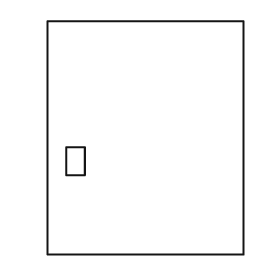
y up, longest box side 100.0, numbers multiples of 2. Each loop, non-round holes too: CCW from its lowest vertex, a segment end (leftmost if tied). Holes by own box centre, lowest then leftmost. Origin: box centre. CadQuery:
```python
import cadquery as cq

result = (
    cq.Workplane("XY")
    .moveTo(-42.0, -50.0)
    .lineTo(42.0, -50.0)
    .lineTo(42.0, 50.0)
    .lineTo(-42.0, 50.0)
    .close()
    .moveTo(-34.0, -16.0)
    .lineTo(-26.0, -16.0)
    .lineTo(-26.0, -4.0)
    .lineTo(-34.0, -4.0)
    .close()
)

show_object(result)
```